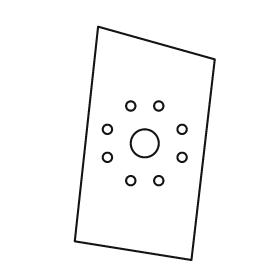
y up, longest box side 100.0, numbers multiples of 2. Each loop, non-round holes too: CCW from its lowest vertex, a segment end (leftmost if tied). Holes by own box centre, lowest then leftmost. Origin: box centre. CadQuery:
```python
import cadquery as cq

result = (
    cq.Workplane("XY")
    .moveTo(20.0, -50.0)
    .lineTo(30.0, 36.0)
    .lineTo(-20.0, 50.0)
    .lineTo(-30.0, -42.0)
    .close()
    .moveTo(-6.0, -16.0)
    .circle(2.0)
    .moveTo(6.0, -16.0)
    .circle(2.0)
    .moveTo(-16.0, -6.0)
    .circle(2.0)
    .moveTo(16.0, -6.0)
    .circle(2.0)
    .moveTo(0.0, 0.0)
    .circle(6.0)
    .moveTo(-16.0, 6.0)
    .circle(2.0)
    .moveTo(16.0, 6.0)
    .circle(2.0)
    .moveTo(-6.0, 16.0)
    .circle(2.0)
    .moveTo(6.0, 16.0)
    .circle(2.0)
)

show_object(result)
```